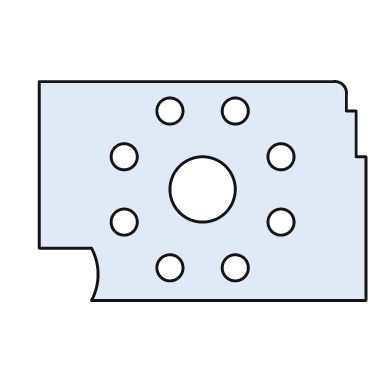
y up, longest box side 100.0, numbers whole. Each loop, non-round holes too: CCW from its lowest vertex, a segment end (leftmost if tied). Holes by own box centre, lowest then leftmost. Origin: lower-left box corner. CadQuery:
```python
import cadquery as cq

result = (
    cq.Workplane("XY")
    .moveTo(16.0, 0.0)
    .lineTo(100.0, 0.0)
    .lineTo(100.0, 44.0)
    .lineTo(97.0, 44.0)
    .lineTo(97.0, 58.0)
    .lineTo(94.0, 58.0)
    .lineTo(94.0, 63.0)
    .threePointArc((93.0, 66.0), (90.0, 67.0))
    .lineTo(0.0, 67.0)
    .lineTo(0.0, 16.0)
    .lineTo(16.0, 16.0)
    .threePointArc((18.0, 8.0), (16.0, 0.0))
    .close()
    .moveTo(40.0, 10.0)
    .circle(4.0)
    .moveTo(60.0, 10.0)
    .circle(4.0)
    .moveTo(26.0, 24.0)
    .circle(4.0)
    .moveTo(74.0, 24.0)
    .circle(4.0)
    .moveTo(50.0, 34.0)
    .circle(10.0)
    .moveTo(26.0, 44.0)
    .circle(4.0)
    .moveTo(74.0, 44.0)
    .circle(4.0)
    .moveTo(40.0, 58.0)
    .circle(4.0)
    .moveTo(60.0, 58.0)
    .circle(4.0)
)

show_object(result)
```